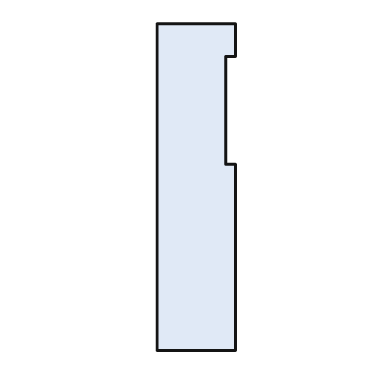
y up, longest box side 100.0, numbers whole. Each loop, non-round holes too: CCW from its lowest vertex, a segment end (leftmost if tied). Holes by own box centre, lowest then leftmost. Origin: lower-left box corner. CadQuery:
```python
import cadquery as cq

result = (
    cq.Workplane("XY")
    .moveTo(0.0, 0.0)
    .lineTo(24.0, 0.0)
    .lineTo(24.0, 57.0)
    .lineTo(21.0, 57.0)
    .lineTo(21.0, 90.0)
    .lineTo(24.0, 90.0)
    .lineTo(24.0, 100.0)
    .lineTo(0.0, 100.0)
    .close()
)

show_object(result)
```